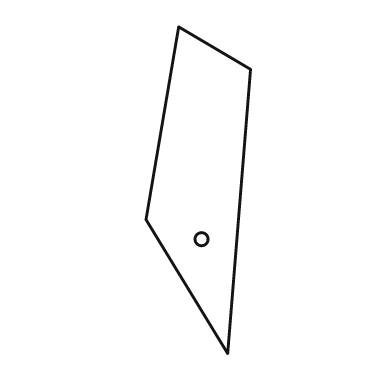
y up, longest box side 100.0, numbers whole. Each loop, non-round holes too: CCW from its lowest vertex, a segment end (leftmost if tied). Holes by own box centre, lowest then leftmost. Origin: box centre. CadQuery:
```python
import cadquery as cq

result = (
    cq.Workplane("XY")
    .moveTo(9.0, -50.0)
    .lineTo(16.0, 37.0)
    .lineTo(-6.0, 50.0)
    .lineTo(-16.0, -9.0)
    .close()
    .moveTo(1.0, -15.0)
    .circle(2.0)
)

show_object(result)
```